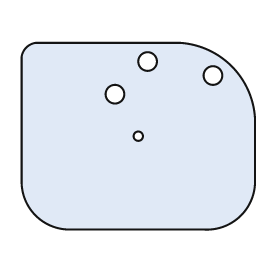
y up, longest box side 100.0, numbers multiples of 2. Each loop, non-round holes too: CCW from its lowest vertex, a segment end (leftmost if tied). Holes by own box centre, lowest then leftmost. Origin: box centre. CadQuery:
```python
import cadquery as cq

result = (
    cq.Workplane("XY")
    .moveTo(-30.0, -40.0)
    .lineTo(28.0, -40.0)
    .threePointArc((44.0, -34.0), (50.0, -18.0))
    .lineTo(50.0, 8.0)
    .threePointArc((40.0, 30.0), (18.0, 40.0))
    .lineTo(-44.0, 40.0)
    .threePointArc((-48.0, 38.0), (-50.0, 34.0))
    .lineTo(-50.0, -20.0)
    .threePointArc((-44.0, -34.0), (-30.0, -40.0))
    .close()
    .moveTo(0.0, 0.0)
    .circle(2.0)
    .moveTo(-10.0, 18.0)
    .circle(4.0)
    .moveTo(32.0, 26.0)
    .circle(4.0)
    .moveTo(4.0, 32.0)
    .circle(4.0)
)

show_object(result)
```